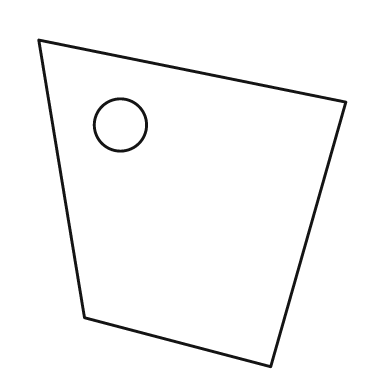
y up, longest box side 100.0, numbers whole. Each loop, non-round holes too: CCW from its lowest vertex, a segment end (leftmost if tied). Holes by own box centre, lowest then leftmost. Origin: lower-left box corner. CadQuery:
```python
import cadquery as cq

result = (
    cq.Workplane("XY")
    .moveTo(71.0, 0.0)
    .lineTo(94.0, 81.0)
    .lineTo(0.0, 100.0)
    .lineTo(14.0, 15.0)
    .close()
    .moveTo(25.0, 74.0)
    .circle(8.0)
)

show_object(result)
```